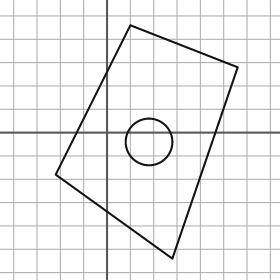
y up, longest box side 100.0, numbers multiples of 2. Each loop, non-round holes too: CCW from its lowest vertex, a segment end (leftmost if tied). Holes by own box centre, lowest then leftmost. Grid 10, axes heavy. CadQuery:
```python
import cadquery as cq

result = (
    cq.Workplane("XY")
    .moveTo(28.0, -54.0)
    .lineTo(56.0, 28.0)
    .lineTo(10.0, 46.0)
    .lineTo(-22.0, -18.0)
    .close()
    .moveTo(18.0, -4.0)
    .circle(10.0)
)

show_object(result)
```